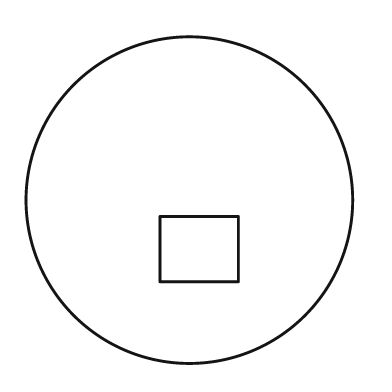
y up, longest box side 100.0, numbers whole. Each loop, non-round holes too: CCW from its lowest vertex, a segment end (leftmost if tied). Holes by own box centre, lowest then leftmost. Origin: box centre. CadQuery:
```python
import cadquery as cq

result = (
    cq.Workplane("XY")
    .moveTo(0.0, 0.0)
    .circle(50.0)
    .moveTo(-9.0, -25.0)
    .lineTo(15.0, -25.0)
    .lineTo(15.0, -5.0)
    .lineTo(-9.0, -5.0)
    .close()
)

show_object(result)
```